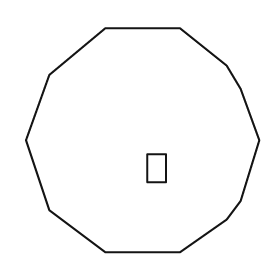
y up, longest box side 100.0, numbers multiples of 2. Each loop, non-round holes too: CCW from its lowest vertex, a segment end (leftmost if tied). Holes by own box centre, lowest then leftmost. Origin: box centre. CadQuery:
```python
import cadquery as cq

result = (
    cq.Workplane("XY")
    .moveTo(-16.0, -48.0)
    .lineTo(16.0, -48.0)
    .lineTo(36.0, -34.0)
    .lineTo(42.0, -26.0)
    .lineTo(50.0, 0.0)
    .lineTo(42.0, 22.0)
    .lineTo(36.0, 32.0)
    .lineTo(16.0, 48.0)
    .lineTo(-16.0, 48.0)
    .lineTo(-40.0, 28.0)
    .lineTo(-50.0, 0.0)
    .lineTo(-40.0, -30.0)
    .close()
    .moveTo(2.0, -18.0)
    .lineTo(10.0, -18.0)
    .lineTo(10.0, -6.0)
    .lineTo(2.0, -6.0)
    .close()
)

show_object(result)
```